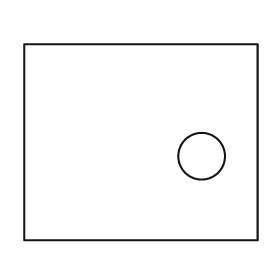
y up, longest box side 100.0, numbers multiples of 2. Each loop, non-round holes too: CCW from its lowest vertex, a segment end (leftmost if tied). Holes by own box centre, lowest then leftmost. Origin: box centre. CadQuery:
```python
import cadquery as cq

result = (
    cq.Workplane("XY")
    .moveTo(-50.0, -42.0)
    .lineTo(50.0, -42.0)
    .lineTo(50.0, 42.0)
    .lineTo(-50.0, 42.0)
    .close()
    .moveTo(26.0, -6.0)
    .circle(10.0)
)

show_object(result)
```